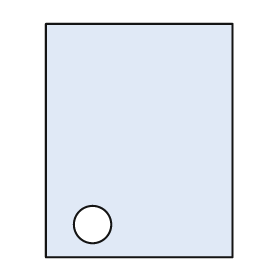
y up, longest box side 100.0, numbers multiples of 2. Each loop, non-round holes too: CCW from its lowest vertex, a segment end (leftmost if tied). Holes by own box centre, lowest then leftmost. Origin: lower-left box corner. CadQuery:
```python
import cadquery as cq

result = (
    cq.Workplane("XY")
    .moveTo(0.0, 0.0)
    .lineTo(80.0, 0.0)
    .lineTo(80.0, 100.0)
    .lineTo(0.0, 100.0)
    .close()
    .moveTo(20.0, 14.0)
    .circle(8.0)
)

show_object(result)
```